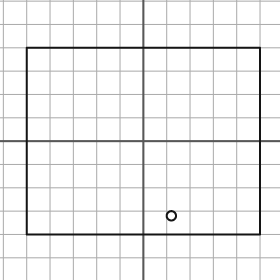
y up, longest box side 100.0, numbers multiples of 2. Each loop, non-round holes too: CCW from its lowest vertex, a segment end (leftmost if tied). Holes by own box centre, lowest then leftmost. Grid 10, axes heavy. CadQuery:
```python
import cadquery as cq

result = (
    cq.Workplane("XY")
    .moveTo(-50.0, -40.0)
    .lineTo(50.0, -40.0)
    .lineTo(50.0, 40.0)
    .lineTo(-50.0, 40.0)
    .close()
    .moveTo(12.0, -32.0)
    .circle(2.0)
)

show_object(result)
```